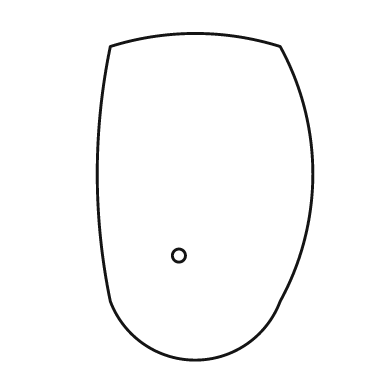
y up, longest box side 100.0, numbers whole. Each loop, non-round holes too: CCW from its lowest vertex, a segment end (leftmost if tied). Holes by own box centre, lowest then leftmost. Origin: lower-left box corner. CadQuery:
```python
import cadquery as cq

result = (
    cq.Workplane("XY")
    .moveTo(4.0, 18.0)
    .threePointArc((30.0, 0.0), (56.0, 18.0))
    .threePointArc((66.0, 57.0), (56.0, 96.0))
    .threePointArc((30.0, 100.0), (4.0, 96.0))
    .threePointArc((0.0, 57.0), (4.0, 18.0))
    .close()
    .moveTo(25.0, 32.0)
    .circle(2.0)
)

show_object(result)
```